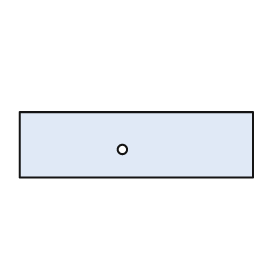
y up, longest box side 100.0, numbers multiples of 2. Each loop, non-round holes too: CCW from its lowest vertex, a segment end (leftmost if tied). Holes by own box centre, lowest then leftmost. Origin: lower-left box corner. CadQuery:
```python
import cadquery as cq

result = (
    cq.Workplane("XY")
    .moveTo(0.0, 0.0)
    .lineTo(100.0, 0.0)
    .lineTo(100.0, 28.0)
    .lineTo(0.0, 28.0)
    .close()
    .moveTo(44.0, 12.0)
    .circle(2.0)
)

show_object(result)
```